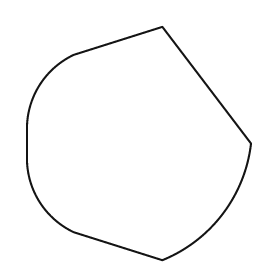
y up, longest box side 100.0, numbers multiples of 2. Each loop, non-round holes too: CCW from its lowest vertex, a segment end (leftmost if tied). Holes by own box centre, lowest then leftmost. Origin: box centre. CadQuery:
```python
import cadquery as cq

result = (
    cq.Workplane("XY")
    .moveTo(10.0, -50.0)
    .threePointArc((36.0, -30.0), (48.0, 0.0))
    .lineTo(10.0, 50.0)
    .lineTo(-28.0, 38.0)
    .threePointArc((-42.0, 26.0), (-48.0, 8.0))
    .lineTo(-48.0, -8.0)
    .threePointArc((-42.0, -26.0), (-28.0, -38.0))
    .close()
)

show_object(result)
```